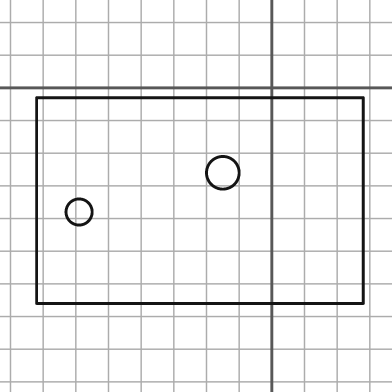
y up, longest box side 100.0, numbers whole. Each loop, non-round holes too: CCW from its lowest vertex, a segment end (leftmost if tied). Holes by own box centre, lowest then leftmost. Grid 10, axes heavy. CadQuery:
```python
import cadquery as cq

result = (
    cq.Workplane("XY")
    .moveTo(-72.0, -66.0)
    .lineTo(28.0, -66.0)
    .lineTo(28.0, -3.0)
    .lineTo(-72.0, -3.0)
    .close()
    .moveTo(-59.0, -38.0)
    .circle(4.0)
    .moveTo(-15.0, -26.0)
    .circle(5.0)
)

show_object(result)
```